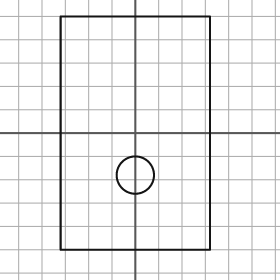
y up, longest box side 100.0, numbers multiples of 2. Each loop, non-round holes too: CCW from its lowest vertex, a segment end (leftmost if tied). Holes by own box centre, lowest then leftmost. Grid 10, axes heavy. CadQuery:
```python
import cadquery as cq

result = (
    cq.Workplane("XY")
    .moveTo(-32.0, -50.0)
    .lineTo(32.0, -50.0)
    .lineTo(32.0, 50.0)
    .lineTo(-32.0, 50.0)
    .close()
    .moveTo(0.0, -18.0)
    .circle(8.0)
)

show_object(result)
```